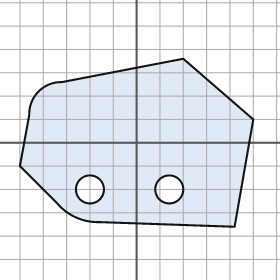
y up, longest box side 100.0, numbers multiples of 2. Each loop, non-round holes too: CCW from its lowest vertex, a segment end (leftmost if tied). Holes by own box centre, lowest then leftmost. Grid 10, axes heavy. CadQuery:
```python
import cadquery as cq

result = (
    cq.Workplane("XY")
    .moveTo(42.0, -36.0)
    .lineTo(50.0, 10.0)
    .lineTo(20.0, 36.0)
    .lineTo(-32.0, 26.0)
    .threePointArc((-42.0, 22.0), (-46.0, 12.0))
    .lineTo(-50.0, -10.0)
    .lineTo(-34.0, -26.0)
    .threePointArc((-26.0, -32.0), (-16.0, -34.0))
    .close()
    .moveTo(-20.0, -20.0)
    .circle(6.0)
    .moveTo(14.0, -20.0)
    .circle(6.0)
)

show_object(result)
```